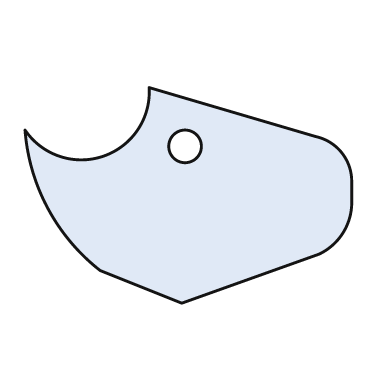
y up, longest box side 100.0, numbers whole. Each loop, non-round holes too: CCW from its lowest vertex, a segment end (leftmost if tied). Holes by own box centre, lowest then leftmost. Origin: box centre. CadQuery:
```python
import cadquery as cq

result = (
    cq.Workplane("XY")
    .moveTo(-2.0, -33.0)
    .lineTo(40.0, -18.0)
    .threePointArc((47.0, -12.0), (50.0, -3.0))
    .lineTo(50.0, 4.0)
    .threePointArc((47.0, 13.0), (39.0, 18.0))
    .lineTo(-12.0, 33.0)
    .threePointArc((-26.0, 12.0), (-50.0, 20.0))
    .threePointArc((-43.0, -4.0), (-27.0, -23.0))
    .close()
    .moveTo(-1.0, 15.0)
    .circle(5.0)
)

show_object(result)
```